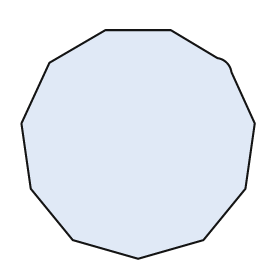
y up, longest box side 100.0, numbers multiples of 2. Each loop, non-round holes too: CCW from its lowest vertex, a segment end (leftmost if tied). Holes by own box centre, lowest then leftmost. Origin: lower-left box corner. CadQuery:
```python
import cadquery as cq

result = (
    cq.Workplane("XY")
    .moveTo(50.0, 0.0)
    .lineTo(78.0, 8.0)
    .lineTo(96.0, 30.0)
    .lineTo(100.0, 58.0)
    .lineTo(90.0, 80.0)
    .threePointArc((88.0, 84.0), (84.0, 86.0))
    .lineTo(64.0, 98.0)
    .lineTo(36.0, 98.0)
    .lineTo(12.0, 84.0)
    .lineTo(0.0, 58.0)
    .lineTo(4.0, 30.0)
    .lineTo(22.0, 8.0)
    .close()
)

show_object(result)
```